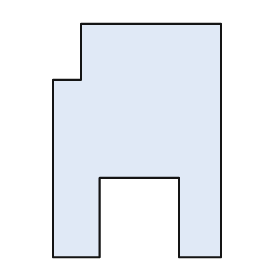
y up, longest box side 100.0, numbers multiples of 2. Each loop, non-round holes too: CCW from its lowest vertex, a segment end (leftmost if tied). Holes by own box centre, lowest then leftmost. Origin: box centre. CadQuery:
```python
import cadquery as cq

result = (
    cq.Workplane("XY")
    .moveTo(-36.0, -50.0)
    .lineTo(-16.0, -50.0)
    .lineTo(-16.0, -16.0)
    .lineTo(18.0, -16.0)
    .lineTo(18.0, -50.0)
    .lineTo(36.0, -50.0)
    .lineTo(36.0, 50.0)
    .lineTo(-24.0, 50.0)
    .lineTo(-24.0, 26.0)
    .lineTo(-36.0, 26.0)
    .close()
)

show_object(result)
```